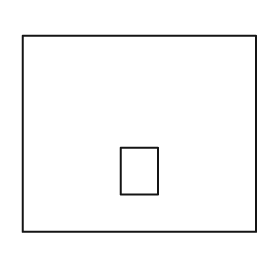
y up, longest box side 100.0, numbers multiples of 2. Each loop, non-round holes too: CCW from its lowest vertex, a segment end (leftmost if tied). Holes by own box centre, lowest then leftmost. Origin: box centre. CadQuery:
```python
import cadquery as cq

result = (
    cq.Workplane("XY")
    .moveTo(-50.0, -42.0)
    .lineTo(50.0, -42.0)
    .lineTo(50.0, 42.0)
    .lineTo(-50.0, 42.0)
    .close()
    .moveTo(-8.0, -26.0)
    .lineTo(8.0, -26.0)
    .lineTo(8.0, -6.0)
    .lineTo(-8.0, -6.0)
    .close()
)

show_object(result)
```